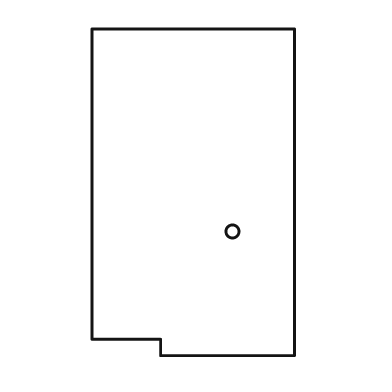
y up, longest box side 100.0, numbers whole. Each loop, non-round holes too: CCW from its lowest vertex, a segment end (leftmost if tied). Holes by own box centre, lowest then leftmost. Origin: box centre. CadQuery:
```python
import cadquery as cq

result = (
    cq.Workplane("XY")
    .moveTo(-10.0, -50.0)
    .lineTo(31.0, -50.0)
    .lineTo(31.0, 50.0)
    .lineTo(-31.0, 50.0)
    .lineTo(-31.0, -45.0)
    .lineTo(-10.0, -45.0)
    .close()
    .moveTo(12.0, -12.0)
    .circle(2.0)
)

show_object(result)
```